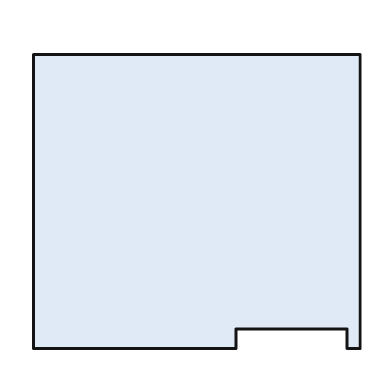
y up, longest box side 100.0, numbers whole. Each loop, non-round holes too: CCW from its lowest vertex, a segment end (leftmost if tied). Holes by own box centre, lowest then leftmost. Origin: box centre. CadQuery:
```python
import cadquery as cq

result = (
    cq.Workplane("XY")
    .moveTo(-50.0, -45.0)
    .lineTo(12.0, -45.0)
    .lineTo(12.0, -39.0)
    .lineTo(46.0, -39.0)
    .lineTo(46.0, -45.0)
    .lineTo(50.0, -45.0)
    .lineTo(50.0, 45.0)
    .lineTo(-50.0, 45.0)
    .close()
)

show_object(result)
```